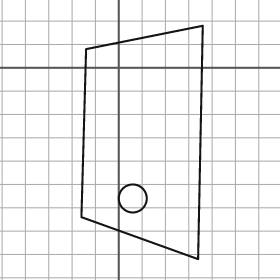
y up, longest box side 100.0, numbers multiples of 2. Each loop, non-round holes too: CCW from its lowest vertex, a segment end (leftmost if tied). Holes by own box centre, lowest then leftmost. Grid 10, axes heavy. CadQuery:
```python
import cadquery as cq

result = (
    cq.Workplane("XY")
    .moveTo(34.0, -82.0)
    .lineTo(36.0, 18.0)
    .lineTo(-14.0, 8.0)
    .lineTo(-16.0, -64.0)
    .close()
    .moveTo(6.0, -56.0)
    .circle(6.0)
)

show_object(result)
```